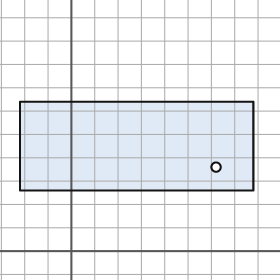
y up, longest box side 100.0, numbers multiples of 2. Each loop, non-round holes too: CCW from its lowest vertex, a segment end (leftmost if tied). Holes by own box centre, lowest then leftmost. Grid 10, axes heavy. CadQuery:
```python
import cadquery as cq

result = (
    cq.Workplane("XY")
    .moveTo(-22.0, 26.0)
    .lineTo(78.0, 26.0)
    .lineTo(78.0, 64.0)
    .lineTo(-22.0, 64.0)
    .close()
    .moveTo(62.0, 36.0)
    .circle(2.0)
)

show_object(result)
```